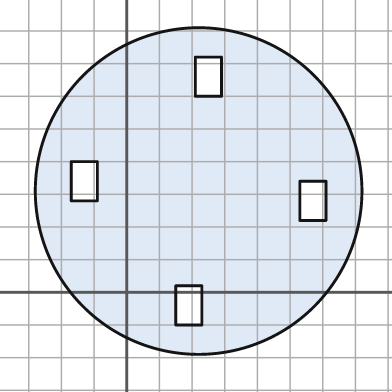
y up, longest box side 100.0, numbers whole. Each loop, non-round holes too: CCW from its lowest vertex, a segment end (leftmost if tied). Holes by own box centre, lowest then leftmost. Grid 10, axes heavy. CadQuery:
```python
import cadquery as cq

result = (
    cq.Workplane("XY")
    .moveTo(22.0, 31.0)
    .circle(50.0)
    .moveTo(15.0, -10.0)
    .lineTo(23.0, -10.0)
    .lineTo(23.0, 2.0)
    .lineTo(15.0, 2.0)
    .close()
    .moveTo(53.0, 22.0)
    .lineTo(61.0, 22.0)
    .lineTo(61.0, 34.0)
    .lineTo(53.0, 34.0)
    .close()
    .moveTo(-17.0, 28.0)
    .lineTo(-9.0, 28.0)
    .lineTo(-9.0, 40.0)
    .lineTo(-17.0, 40.0)
    .close()
    .moveTo(21.0, 60.0)
    .lineTo(29.0, 60.0)
    .lineTo(29.0, 72.0)
    .lineTo(21.0, 72.0)
    .close()
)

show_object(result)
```